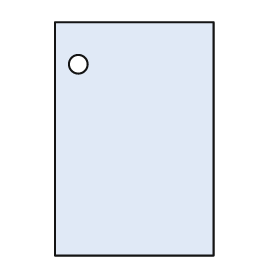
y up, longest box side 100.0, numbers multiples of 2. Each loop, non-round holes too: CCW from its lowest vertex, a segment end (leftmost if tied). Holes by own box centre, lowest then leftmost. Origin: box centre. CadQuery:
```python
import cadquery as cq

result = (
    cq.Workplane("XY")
    .moveTo(-34.0, -50.0)
    .lineTo(34.0, -50.0)
    .lineTo(34.0, 50.0)
    .lineTo(-34.0, 50.0)
    .close()
    .moveTo(-24.0, 32.0)
    .circle(4.0)
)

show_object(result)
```